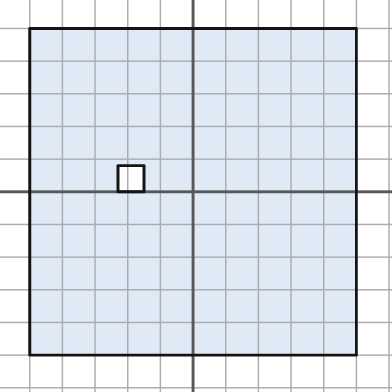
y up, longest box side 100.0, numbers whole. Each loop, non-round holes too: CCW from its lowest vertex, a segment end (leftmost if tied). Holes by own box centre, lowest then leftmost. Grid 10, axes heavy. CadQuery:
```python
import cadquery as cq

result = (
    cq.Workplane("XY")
    .moveTo(-50.0, -50.0)
    .lineTo(50.0, -50.0)
    .lineTo(50.0, 50.0)
    .lineTo(-50.0, 50.0)
    .close()
    .moveTo(-23.0, 0.0)
    .lineTo(-15.0, 0.0)
    .lineTo(-15.0, 8.0)
    .lineTo(-23.0, 8.0)
    .close()
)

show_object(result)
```